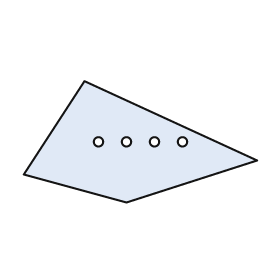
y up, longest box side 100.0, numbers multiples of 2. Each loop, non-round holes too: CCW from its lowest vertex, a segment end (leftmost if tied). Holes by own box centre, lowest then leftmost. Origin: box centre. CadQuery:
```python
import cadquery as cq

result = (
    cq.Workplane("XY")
    .moveTo(-6.0, -26.0)
    .lineTo(50.0, -8.0)
    .lineTo(-24.0, 26.0)
    .lineTo(-50.0, -14.0)
    .close()
    .moveTo(-18.0, 0.0)
    .circle(2.0)
    .moveTo(-6.0, 0.0)
    .circle(2.0)
    .moveTo(6.0, 0.0)
    .circle(2.0)
    .moveTo(18.0, 0.0)
    .circle(2.0)
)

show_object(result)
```